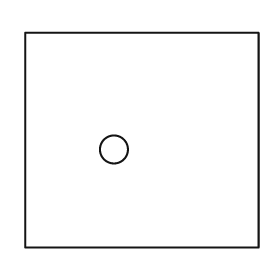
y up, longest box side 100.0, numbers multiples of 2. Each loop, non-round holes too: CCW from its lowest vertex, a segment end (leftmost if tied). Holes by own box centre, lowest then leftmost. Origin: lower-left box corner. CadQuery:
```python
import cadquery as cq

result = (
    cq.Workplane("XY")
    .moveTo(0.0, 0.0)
    .lineTo(100.0, 0.0)
    .lineTo(100.0, 92.0)
    .lineTo(0.0, 92.0)
    .close()
    .moveTo(38.0, 42.0)
    .circle(6.0)
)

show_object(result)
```